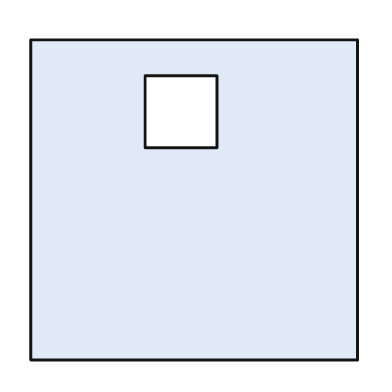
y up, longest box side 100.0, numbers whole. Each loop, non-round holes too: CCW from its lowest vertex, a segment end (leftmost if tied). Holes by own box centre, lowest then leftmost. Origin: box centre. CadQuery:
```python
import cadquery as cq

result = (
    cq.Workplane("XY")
    .moveTo(-50.0, -49.0)
    .lineTo(50.0, -49.0)
    .lineTo(50.0, 49.0)
    .lineTo(-50.0, 49.0)
    .close()
    .moveTo(-15.0, 16.0)
    .lineTo(7.0, 16.0)
    .lineTo(7.0, 38.0)
    .lineTo(-15.0, 38.0)
    .close()
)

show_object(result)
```